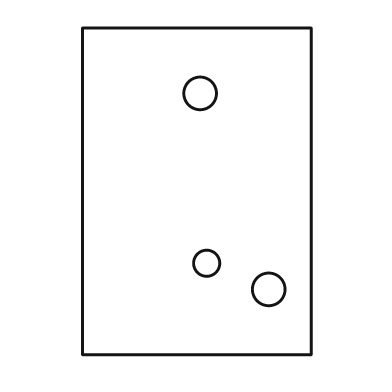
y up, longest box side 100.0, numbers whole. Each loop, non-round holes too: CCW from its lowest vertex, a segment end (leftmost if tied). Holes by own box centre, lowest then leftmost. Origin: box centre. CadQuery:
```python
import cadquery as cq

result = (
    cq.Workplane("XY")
    .moveTo(-35.0, -50.0)
    .lineTo(35.0, -50.0)
    .lineTo(35.0, 50.0)
    .lineTo(-35.0, 50.0)
    .close()
    .moveTo(22.0, -30.0)
    .circle(5.0)
    .moveTo(3.0, -22.0)
    .circle(4.0)
    .moveTo(1.0, 30.0)
    .circle(5.0)
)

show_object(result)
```